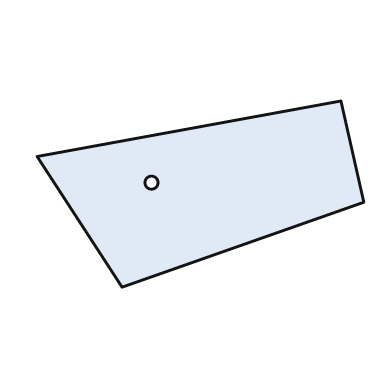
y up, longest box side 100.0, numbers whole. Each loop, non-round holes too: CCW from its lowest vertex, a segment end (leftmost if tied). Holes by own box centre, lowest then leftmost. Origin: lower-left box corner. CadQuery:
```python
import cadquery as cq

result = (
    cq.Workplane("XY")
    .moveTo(26.0, 0.0)
    .lineTo(100.0, 26.0)
    .lineTo(93.0, 57.0)
    .lineTo(0.0, 40.0)
    .close()
    .moveTo(35.0, 32.0)
    .circle(2.0)
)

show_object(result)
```